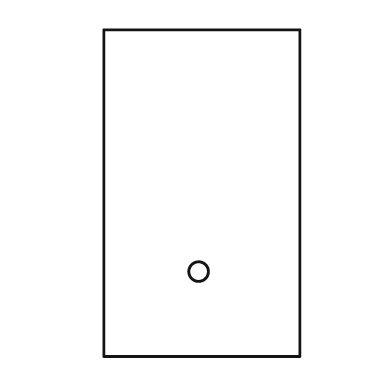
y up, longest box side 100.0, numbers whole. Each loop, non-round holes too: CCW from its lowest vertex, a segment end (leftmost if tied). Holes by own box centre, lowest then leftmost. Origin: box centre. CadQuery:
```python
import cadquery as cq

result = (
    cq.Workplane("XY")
    .moveTo(-30.0, -50.0)
    .lineTo(30.0, -50.0)
    .lineTo(30.0, 50.0)
    .lineTo(-30.0, 50.0)
    .close()
    .moveTo(-1.0, -24.0)
    .circle(3.0)
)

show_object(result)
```